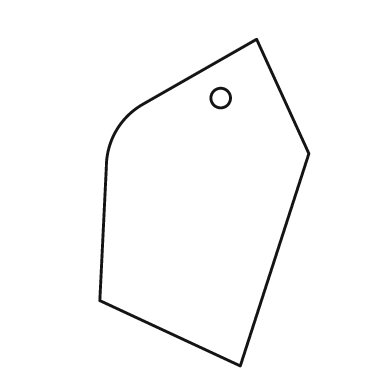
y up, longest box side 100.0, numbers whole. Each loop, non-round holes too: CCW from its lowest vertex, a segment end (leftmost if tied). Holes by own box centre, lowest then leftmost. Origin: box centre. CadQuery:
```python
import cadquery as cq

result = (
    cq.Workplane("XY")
    .moveTo(11.0, -50.0)
    .lineTo(32.0, 15.0)
    .lineTo(16.0, 50.0)
    .lineTo(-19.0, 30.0)
    .threePointArc((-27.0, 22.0), (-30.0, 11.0))
    .lineTo(-32.0, -30.0)
    .close()
    .moveTo(5.0, 32.0)
    .circle(3.0)
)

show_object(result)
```